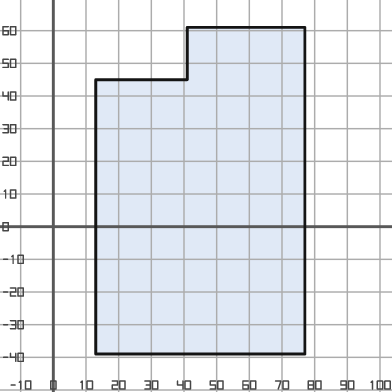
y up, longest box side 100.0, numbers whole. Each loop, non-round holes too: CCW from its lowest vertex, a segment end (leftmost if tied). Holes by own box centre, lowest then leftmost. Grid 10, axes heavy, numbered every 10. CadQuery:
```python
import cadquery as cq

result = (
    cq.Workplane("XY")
    .moveTo(13.0, -39.0)
    .lineTo(77.0, -39.0)
    .lineTo(77.0, 61.0)
    .lineTo(41.0, 61.0)
    .lineTo(41.0, 45.0)
    .lineTo(13.0, 45.0)
    .close()
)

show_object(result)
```